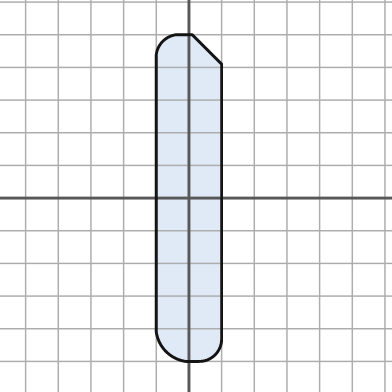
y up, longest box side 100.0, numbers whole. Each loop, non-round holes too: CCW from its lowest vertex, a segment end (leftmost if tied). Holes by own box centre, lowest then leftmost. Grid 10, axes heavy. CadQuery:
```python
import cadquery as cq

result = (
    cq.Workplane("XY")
    .moveTo(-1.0, -50.0)
    .lineTo(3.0, -50.0)
    .threePointArc((8.0, -48.0), (10.0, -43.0))
    .lineTo(10.0, 41.0)
    .lineTo(1.0, 50.0)
    .lineTo(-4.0, 50.0)
    .threePointArc((-8.0, 48.0), (-10.0, 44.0))
    .lineTo(-10.0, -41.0)
    .threePointArc((-7.0, -47.0), (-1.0, -50.0))
    .close()
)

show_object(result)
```